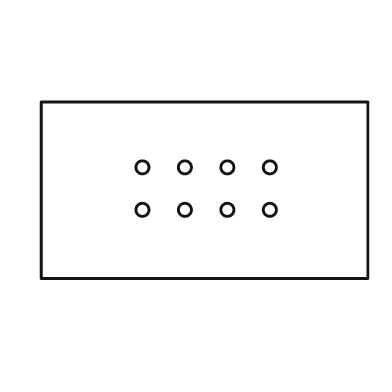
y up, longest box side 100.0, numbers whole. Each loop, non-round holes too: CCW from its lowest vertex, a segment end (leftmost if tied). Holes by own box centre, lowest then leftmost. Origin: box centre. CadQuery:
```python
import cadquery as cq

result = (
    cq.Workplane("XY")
    .moveTo(-50.0, -27.0)
    .lineTo(50.0, -27.0)
    .lineTo(50.0, 27.0)
    .lineTo(-50.0, 27.0)
    .close()
    .moveTo(-19.0, -6.0)
    .circle(2.0)
    .moveTo(-6.0, -6.0)
    .circle(2.0)
    .moveTo(7.0, -6.0)
    .circle(2.0)
    .moveTo(20.0, -6.0)
    .circle(2.0)
    .moveTo(-19.0, 7.0)
    .circle(2.0)
    .moveTo(-6.0, 7.0)
    .circle(2.0)
    .moveTo(7.0, 7.0)
    .circle(2.0)
    .moveTo(20.0, 7.0)
    .circle(2.0)
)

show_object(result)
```